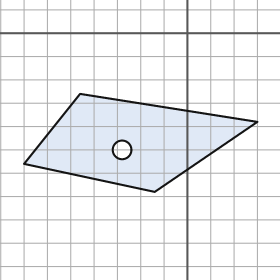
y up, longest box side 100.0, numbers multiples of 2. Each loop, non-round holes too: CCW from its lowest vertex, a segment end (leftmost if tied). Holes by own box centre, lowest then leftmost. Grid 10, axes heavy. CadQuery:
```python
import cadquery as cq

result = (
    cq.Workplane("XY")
    .moveTo(-14.0, -68.0)
    .lineTo(30.0, -38.0)
    .lineTo(-46.0, -26.0)
    .lineTo(-70.0, -56.0)
    .close()
    .moveTo(-28.0, -50.0)
    .circle(4.0)
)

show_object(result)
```